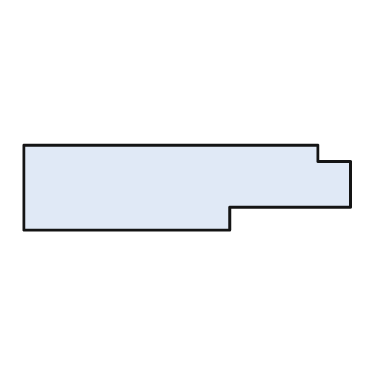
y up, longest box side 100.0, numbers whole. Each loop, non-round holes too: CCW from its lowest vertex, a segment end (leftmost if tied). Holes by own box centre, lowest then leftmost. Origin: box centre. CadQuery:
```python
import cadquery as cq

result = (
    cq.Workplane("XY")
    .moveTo(-50.0, -13.0)
    .lineTo(13.0, -13.0)
    .lineTo(13.0, -6.0)
    .lineTo(50.0, -6.0)
    .lineTo(50.0, 8.0)
    .lineTo(40.0, 8.0)
    .lineTo(40.0, 13.0)
    .lineTo(-50.0, 13.0)
    .close()
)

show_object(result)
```